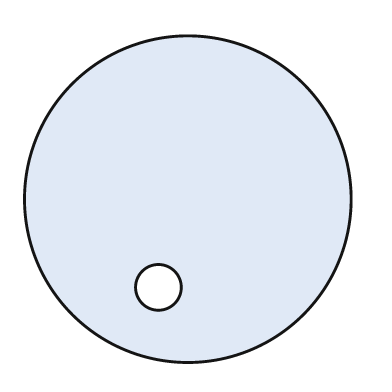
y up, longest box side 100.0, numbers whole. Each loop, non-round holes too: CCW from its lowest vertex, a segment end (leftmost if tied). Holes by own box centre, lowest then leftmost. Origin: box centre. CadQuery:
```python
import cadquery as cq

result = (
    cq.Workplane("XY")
    .moveTo(0.0, 0.0)
    .circle(50.0)
    .moveTo(-9.0, -27.0)
    .circle(7.0)
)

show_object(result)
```